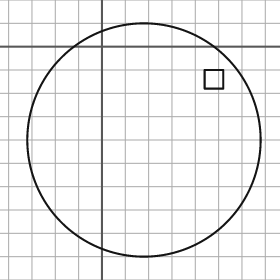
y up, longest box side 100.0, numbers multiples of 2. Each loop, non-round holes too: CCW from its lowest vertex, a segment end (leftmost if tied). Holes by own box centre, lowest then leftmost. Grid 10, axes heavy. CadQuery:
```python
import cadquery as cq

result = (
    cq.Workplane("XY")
    .moveTo(18.0, -40.0)
    .circle(50.0)
    .moveTo(44.0, -18.0)
    .lineTo(52.0, -18.0)
    .lineTo(52.0, -10.0)
    .lineTo(44.0, -10.0)
    .close()
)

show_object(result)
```